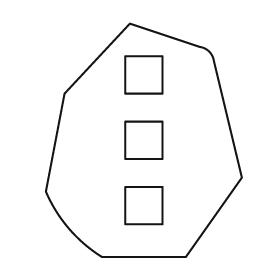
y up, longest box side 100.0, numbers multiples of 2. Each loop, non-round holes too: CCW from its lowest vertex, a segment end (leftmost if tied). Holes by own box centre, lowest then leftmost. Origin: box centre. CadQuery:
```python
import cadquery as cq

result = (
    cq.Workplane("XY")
    .moveTo(-18.0, -50.0)
    .lineTo(18.0, -50.0)
    .lineTo(42.0, -16.0)
    .lineTo(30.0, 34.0)
    .threePointArc((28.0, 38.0), (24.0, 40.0))
    .lineTo(-6.0, 50.0)
    .lineTo(-34.0, 20.0)
    .lineTo(-42.0, -22.0)
    .threePointArc((-32.0, -38.0), (-18.0, -50.0))
    .close()
    .moveTo(-8.0, -36.0)
    .lineTo(8.0, -36.0)
    .lineTo(8.0, -20.0)
    .lineTo(-8.0, -20.0)
    .close()
    .moveTo(-8.0, -8.0)
    .lineTo(8.0, -8.0)
    .lineTo(8.0, 8.0)
    .lineTo(-8.0, 8.0)
    .close()
    .moveTo(-8.0, 20.0)
    .lineTo(8.0, 20.0)
    .lineTo(8.0, 36.0)
    .lineTo(-8.0, 36.0)
    .close()
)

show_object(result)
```